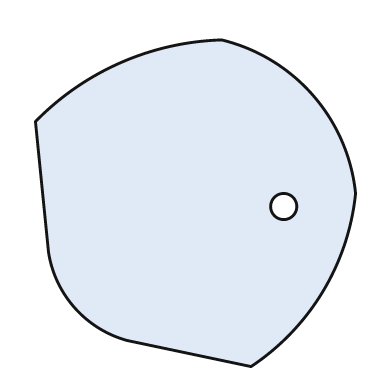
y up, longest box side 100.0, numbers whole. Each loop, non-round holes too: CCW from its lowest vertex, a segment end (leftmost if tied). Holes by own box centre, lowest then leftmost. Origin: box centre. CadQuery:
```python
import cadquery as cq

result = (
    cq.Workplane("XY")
    .moveTo(17.0, -50.0)
    .threePointArc((39.0, -27.0), (49.0, 3.0))
    .threePointArc((36.0, 33.0), (8.0, 50.0))
    .threePointArc((-23.0, 43.0), (-49.0, 25.0))
    .lineTo(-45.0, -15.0)
    .threePointArc((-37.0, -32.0), (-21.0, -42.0))
    .close()
    .moveTo(27.0, -1.0)
    .circle(4.0)
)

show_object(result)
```